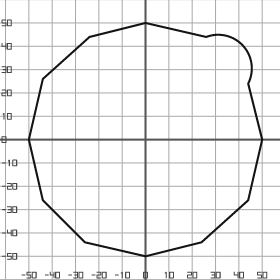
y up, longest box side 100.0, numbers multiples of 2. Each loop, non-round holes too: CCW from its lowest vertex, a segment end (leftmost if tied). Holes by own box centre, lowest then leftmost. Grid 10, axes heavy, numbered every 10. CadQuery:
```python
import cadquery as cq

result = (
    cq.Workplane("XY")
    .moveTo(0.0, -50.0)
    .lineTo(24.0, -44.0)
    .lineTo(44.0, -26.0)
    .lineTo(50.0, 0.0)
    .lineTo(44.0, 24.0)
    .threePointArc((42.0, 40.0), (26.0, 44.0))
    .lineTo(0.0, 50.0)
    .lineTo(-24.0, 44.0)
    .lineTo(-44.0, 26.0)
    .lineTo(-50.0, 0.0)
    .lineTo(-44.0, -26.0)
    .lineTo(-26.0, -44.0)
    .close()
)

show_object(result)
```